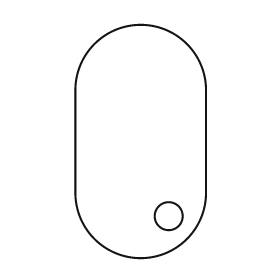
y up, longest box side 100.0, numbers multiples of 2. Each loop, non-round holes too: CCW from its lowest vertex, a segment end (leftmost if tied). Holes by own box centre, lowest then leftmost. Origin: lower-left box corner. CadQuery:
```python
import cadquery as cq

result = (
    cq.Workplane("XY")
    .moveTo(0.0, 28.0)
    .threePointArc((28.0, 0.0), (56.0, 28.0))
    .lineTo(56.0, 72.0)
    .threePointArc((28.0, 100.0), (0.0, 72.0))
    .close()
    .moveTo(40.0, 18.0)
    .circle(6.0)
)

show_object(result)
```